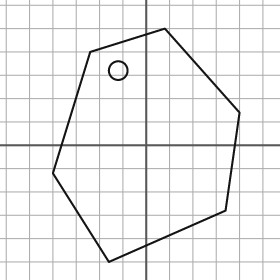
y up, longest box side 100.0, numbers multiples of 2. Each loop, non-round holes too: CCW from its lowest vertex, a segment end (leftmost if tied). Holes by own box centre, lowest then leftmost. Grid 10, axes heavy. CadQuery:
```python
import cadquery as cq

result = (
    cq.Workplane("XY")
    .moveTo(-16.0, -50.0)
    .lineTo(34.0, -28.0)
    .lineTo(40.0, 14.0)
    .lineTo(8.0, 50.0)
    .lineTo(-24.0, 40.0)
    .lineTo(-40.0, -12.0)
    .close()
    .moveTo(-12.0, 32.0)
    .circle(4.0)
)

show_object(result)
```